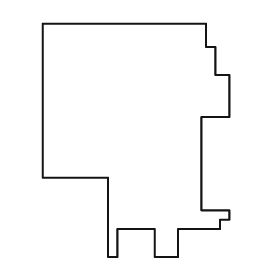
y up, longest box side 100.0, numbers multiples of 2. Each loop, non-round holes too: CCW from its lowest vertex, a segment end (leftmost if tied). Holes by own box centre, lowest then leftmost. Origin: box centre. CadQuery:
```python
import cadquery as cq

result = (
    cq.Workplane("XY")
    .moveTo(-12.0, -50.0)
    .lineTo(-8.0, -50.0)
    .lineTo(-8.0, -38.0)
    .lineTo(8.0, -38.0)
    .lineTo(8.0, -50.0)
    .lineTo(18.0, -50.0)
    .lineTo(18.0, -38.0)
    .lineTo(36.0, -38.0)
    .lineTo(36.0, -34.0)
    .lineTo(40.0, -34.0)
    .lineTo(40.0, -30.0)
    .lineTo(28.0, -30.0)
    .lineTo(28.0, 10.0)
    .lineTo(40.0, 10.0)
    .lineTo(40.0, 28.0)
    .lineTo(34.0, 28.0)
    .lineTo(34.0, 40.0)
    .lineTo(30.0, 40.0)
    .lineTo(30.0, 50.0)
    .lineTo(-40.0, 50.0)
    .lineTo(-40.0, -16.0)
    .lineTo(-12.0, -16.0)
    .close()
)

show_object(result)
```